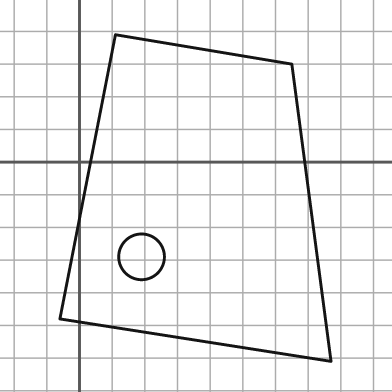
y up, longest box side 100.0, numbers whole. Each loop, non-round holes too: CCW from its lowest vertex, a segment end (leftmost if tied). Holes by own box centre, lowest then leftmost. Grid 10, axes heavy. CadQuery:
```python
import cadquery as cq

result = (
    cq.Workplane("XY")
    .moveTo(77.0, -61.0)
    .lineTo(65.0, 30.0)
    .lineTo(11.0, 39.0)
    .lineTo(-6.0, -48.0)
    .close()
    .moveTo(19.0, -29.0)
    .circle(7.0)
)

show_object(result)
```